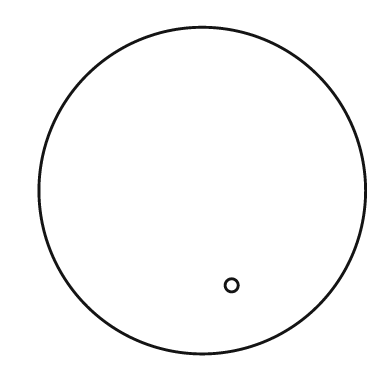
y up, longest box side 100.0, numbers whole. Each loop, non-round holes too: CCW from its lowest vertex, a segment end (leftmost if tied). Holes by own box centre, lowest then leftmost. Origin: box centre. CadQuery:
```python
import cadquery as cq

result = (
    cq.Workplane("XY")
    .moveTo(0.0, 0.0)
    .circle(50.0)
    .moveTo(9.0, -29.0)
    .circle(2.0)
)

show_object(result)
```